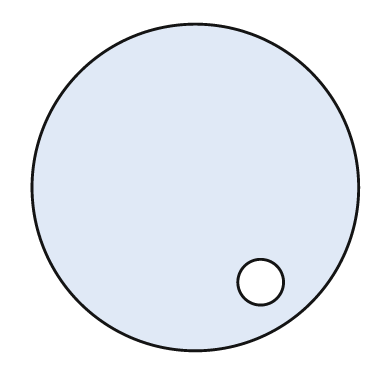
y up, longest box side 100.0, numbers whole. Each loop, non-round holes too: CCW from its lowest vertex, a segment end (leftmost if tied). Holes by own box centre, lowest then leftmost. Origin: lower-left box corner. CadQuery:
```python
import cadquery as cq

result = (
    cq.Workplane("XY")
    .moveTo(50.0, 50.0)
    .circle(50.0)
    .moveTo(70.0, 21.0)
    .circle(7.0)
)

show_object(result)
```